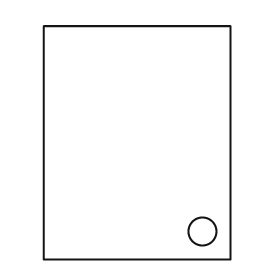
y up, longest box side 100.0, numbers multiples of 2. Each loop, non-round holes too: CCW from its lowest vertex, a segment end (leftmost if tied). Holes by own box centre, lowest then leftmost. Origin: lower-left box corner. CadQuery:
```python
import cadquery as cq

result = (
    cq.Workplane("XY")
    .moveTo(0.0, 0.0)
    .lineTo(80.0, 0.0)
    .lineTo(80.0, 100.0)
    .lineTo(0.0, 100.0)
    .close()
    .moveTo(68.0, 12.0)
    .circle(6.0)
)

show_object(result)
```